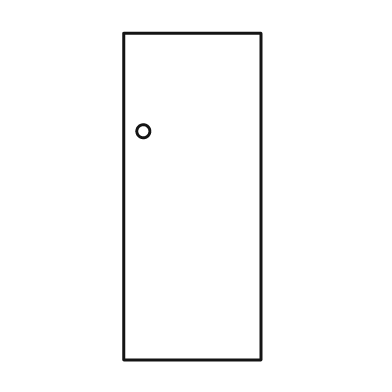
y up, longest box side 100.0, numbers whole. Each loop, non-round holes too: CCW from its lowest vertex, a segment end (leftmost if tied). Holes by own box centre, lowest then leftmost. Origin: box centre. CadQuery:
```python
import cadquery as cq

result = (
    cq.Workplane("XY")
    .moveTo(-21.0, -50.0)
    .lineTo(21.0, -50.0)
    .lineTo(21.0, 50.0)
    .lineTo(-21.0, 50.0)
    .close()
    .moveTo(-15.0, 20.0)
    .circle(2.0)
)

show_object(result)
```